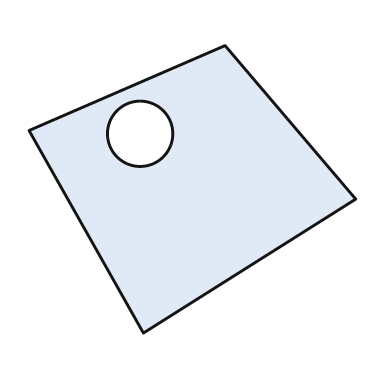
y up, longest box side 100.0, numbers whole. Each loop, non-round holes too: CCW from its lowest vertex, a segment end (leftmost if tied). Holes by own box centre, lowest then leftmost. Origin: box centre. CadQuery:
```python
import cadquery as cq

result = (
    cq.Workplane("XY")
    .moveTo(-15.0, -44.0)
    .lineTo(50.0, -3.0)
    .lineTo(10.0, 44.0)
    .lineTo(-50.0, 18.0)
    .close()
    .moveTo(-16.0, 17.0)
    .circle(10.0)
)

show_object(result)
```